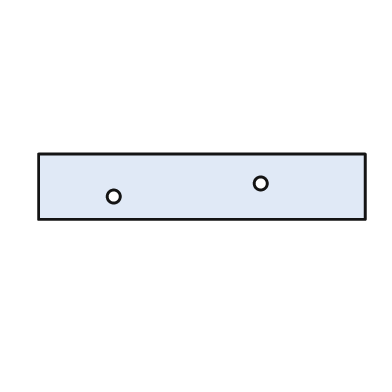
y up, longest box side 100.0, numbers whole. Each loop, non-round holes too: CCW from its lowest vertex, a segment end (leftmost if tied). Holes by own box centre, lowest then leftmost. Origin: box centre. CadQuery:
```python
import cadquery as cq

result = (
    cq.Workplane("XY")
    .moveTo(-50.0, -10.0)
    .lineTo(50.0, -10.0)
    .lineTo(50.0, 10.0)
    .lineTo(-50.0, 10.0)
    .close()
    .moveTo(-27.0, -3.0)
    .circle(2.0)
    .moveTo(18.0, 1.0)
    .circle(2.0)
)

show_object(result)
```